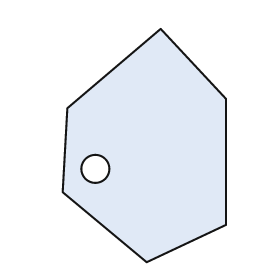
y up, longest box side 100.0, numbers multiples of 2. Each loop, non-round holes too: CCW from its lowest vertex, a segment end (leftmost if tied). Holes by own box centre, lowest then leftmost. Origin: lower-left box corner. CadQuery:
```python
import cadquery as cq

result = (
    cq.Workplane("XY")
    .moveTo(36.0, 0.0)
    .lineTo(70.0, 16.0)
    .lineTo(70.0, 70.0)
    .lineTo(42.0, 100.0)
    .lineTo(2.0, 66.0)
    .lineTo(0.0, 30.0)
    .close()
    .moveTo(14.0, 40.0)
    .circle(6.0)
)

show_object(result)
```